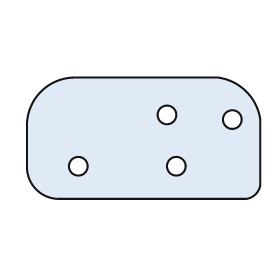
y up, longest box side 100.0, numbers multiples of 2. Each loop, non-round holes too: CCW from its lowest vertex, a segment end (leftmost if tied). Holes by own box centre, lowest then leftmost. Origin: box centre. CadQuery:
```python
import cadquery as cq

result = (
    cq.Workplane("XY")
    .moveTo(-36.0, -26.0)
    .lineTo(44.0, -26.0)
    .threePointArc((48.0, -24.0), (50.0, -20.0))
    .lineTo(50.0, 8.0)
    .threePointArc((44.0, 20.0), (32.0, 26.0))
    .lineTo(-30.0, 26.0)
    .threePointArc((-44.0, 20.0), (-50.0, 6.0))
    .lineTo(-50.0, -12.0)
    .threePointArc((-46.0, -22.0), (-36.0, -26.0))
    .close()
    .moveTo(-28.0, -12.0)
    .circle(4.0)
    .moveTo(14.0, -12.0)
    .circle(4.0)
    .moveTo(38.0, 8.0)
    .circle(4.0)
    .moveTo(10.0, 10.0)
    .circle(4.0)
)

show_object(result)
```